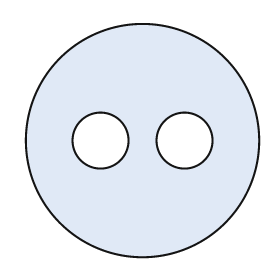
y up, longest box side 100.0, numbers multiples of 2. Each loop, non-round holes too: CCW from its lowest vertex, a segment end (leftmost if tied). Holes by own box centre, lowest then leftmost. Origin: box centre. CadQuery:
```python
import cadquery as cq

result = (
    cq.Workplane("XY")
    .moveTo(0.0, 0.0)
    .circle(50.0)
    .moveTo(-18.0, 0.0)
    .circle(12.0)
    .moveTo(18.0, 0.0)
    .circle(12.0)
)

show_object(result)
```